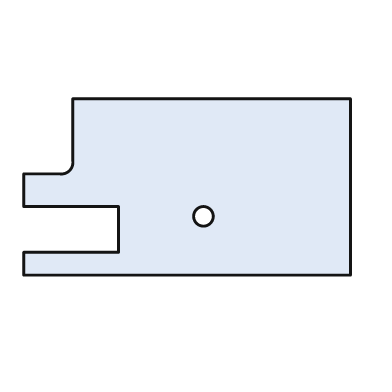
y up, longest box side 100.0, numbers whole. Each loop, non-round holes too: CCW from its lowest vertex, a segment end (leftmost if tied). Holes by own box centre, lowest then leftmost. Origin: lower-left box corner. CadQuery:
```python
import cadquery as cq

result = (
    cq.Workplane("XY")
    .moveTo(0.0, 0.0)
    .lineTo(100.0, 0.0)
    .lineTo(100.0, 54.0)
    .lineTo(15.0, 54.0)
    .lineTo(15.0, 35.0)
    .threePointArc((14.0, 32.0), (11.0, 31.0))
    .lineTo(0.0, 31.0)
    .lineTo(0.0, 21.0)
    .lineTo(29.0, 21.0)
    .lineTo(29.0, 7.0)
    .lineTo(0.0, 7.0)
    .close()
    .moveTo(55.0, 18.0)
    .circle(3.0)
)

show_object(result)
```